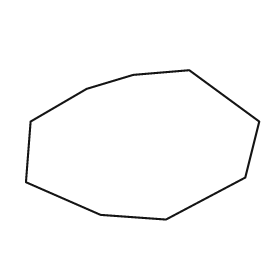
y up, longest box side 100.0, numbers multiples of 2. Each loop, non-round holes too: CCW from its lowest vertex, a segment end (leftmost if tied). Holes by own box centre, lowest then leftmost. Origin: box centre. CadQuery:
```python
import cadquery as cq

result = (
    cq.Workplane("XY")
    .moveTo(10.0, -32.0)
    .lineTo(44.0, -14.0)
    .lineTo(50.0, 10.0)
    .lineTo(20.0, 32.0)
    .lineTo(-4.0, 30.0)
    .lineTo(-24.0, 24.0)
    .lineTo(-48.0, 10.0)
    .lineTo(-50.0, -16.0)
    .lineTo(-18.0, -30.0)
    .close()
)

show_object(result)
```